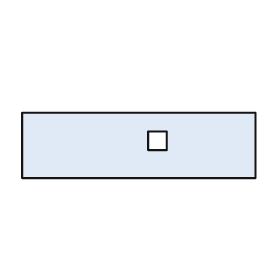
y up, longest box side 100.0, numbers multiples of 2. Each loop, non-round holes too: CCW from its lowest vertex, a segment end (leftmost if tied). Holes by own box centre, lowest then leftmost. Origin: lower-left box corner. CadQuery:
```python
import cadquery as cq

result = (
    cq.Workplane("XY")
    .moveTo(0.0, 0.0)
    .lineTo(100.0, 0.0)
    .lineTo(100.0, 28.0)
    .lineTo(0.0, 28.0)
    .close()
    .moveTo(54.0, 12.0)
    .lineTo(62.0, 12.0)
    .lineTo(62.0, 20.0)
    .lineTo(54.0, 20.0)
    .close()
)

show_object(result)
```